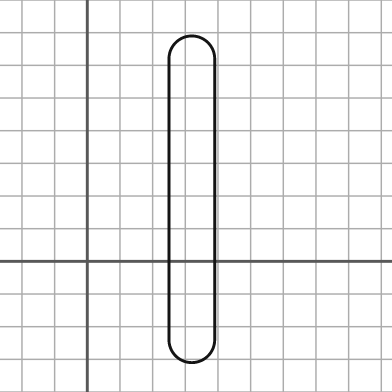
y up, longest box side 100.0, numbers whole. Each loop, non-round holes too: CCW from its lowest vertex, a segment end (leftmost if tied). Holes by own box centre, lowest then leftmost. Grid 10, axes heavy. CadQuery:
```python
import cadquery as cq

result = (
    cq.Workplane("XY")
    .moveTo(25.0, -24.0)
    .threePointArc((32.0, -31.0), (39.0, -24.0))
    .lineTo(39.0, 62.0)
    .threePointArc((32.0, 69.0), (25.0, 62.0))
    .close()
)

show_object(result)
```